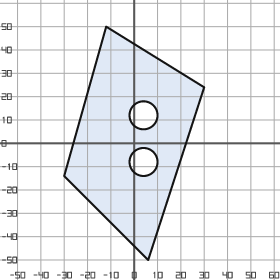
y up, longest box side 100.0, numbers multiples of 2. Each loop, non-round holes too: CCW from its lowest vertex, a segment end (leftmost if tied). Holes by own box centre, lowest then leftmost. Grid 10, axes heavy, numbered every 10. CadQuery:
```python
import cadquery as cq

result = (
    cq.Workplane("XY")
    .moveTo(6.0, -50.0)
    .lineTo(30.0, 24.0)
    .lineTo(-12.0, 50.0)
    .lineTo(-30.0, -14.0)
    .close()
    .moveTo(4.0, -8.0)
    .circle(6.0)
    .moveTo(4.0, 12.0)
    .circle(6.0)
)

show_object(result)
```